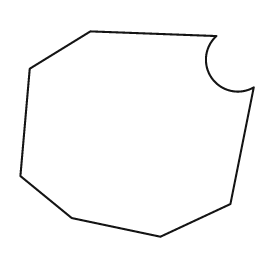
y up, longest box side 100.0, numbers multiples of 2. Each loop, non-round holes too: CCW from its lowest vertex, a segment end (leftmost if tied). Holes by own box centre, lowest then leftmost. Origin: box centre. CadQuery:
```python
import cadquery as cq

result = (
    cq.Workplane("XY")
    .moveTo(10.0, -44.0)
    .lineTo(40.0, -30.0)
    .lineTo(50.0, 20.0)
    .threePointArc((32.0, 24.0), (34.0, 42.0))
    .lineTo(-20.0, 44.0)
    .lineTo(-46.0, 28.0)
    .lineTo(-50.0, -18.0)
    .lineTo(-28.0, -36.0)
    .close()
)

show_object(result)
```